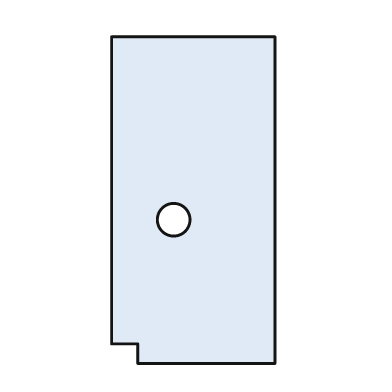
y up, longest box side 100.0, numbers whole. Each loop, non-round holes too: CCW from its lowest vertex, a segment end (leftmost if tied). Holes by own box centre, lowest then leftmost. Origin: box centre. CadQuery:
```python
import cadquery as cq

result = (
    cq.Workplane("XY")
    .moveTo(-17.0, -50.0)
    .lineTo(25.0, -50.0)
    .lineTo(25.0, 50.0)
    .lineTo(-25.0, 50.0)
    .lineTo(-25.0, -44.0)
    .lineTo(-17.0, -44.0)
    .close()
    .moveTo(-6.0, -6.0)
    .circle(5.0)
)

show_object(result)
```